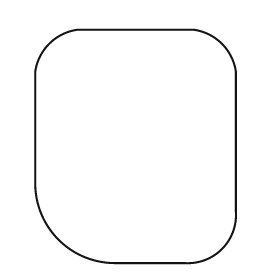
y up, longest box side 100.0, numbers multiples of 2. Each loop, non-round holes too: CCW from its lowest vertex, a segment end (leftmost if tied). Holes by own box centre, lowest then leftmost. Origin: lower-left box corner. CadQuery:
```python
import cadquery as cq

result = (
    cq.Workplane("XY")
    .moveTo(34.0, 0.0)
    .lineTo(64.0, 0.0)
    .threePointArc((80.0, 6.0), (86.0, 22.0))
    .lineTo(86.0, 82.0)
    .threePointArc((80.0, 94.0), (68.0, 100.0))
    .lineTo(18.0, 100.0)
    .threePointArc((6.0, 94.0), (0.0, 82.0))
    .lineTo(0.0, 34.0)
    .threePointArc((10.0, 10.0), (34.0, 0.0))
    .close()
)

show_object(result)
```